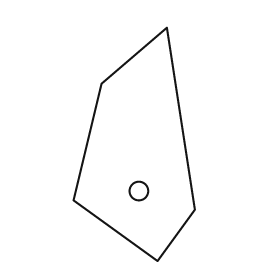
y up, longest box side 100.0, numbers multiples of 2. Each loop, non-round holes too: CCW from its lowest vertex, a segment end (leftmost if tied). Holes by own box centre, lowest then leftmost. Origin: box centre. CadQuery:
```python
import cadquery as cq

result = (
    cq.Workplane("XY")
    .moveTo(10.0, -50.0)
    .lineTo(26.0, -28.0)
    .lineTo(14.0, 50.0)
    .lineTo(-14.0, 26.0)
    .lineTo(-26.0, -24.0)
    .close()
    .moveTo(2.0, -20.0)
    .circle(4.0)
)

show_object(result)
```